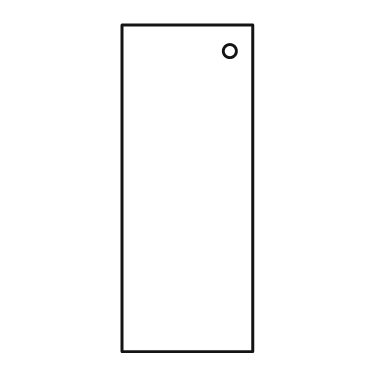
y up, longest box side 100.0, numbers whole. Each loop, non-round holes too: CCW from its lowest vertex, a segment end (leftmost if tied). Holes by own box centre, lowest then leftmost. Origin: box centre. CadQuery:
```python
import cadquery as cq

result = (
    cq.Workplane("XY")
    .moveTo(-20.0, -50.0)
    .lineTo(20.0, -50.0)
    .lineTo(20.0, 50.0)
    .lineTo(-20.0, 50.0)
    .close()
    .moveTo(13.0, 42.0)
    .circle(2.0)
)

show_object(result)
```